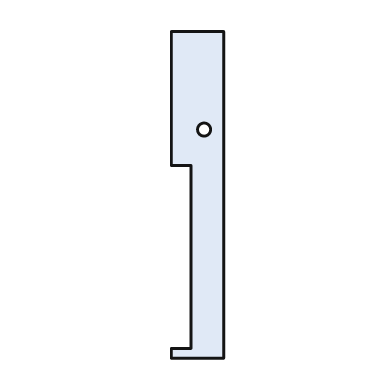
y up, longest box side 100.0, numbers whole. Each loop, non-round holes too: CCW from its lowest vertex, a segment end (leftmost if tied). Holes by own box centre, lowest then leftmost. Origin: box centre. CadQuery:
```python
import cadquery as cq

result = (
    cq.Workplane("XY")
    .moveTo(-8.0, -50.0)
    .lineTo(8.0, -50.0)
    .lineTo(8.0, 50.0)
    .lineTo(-8.0, 50.0)
    .lineTo(-8.0, 9.0)
    .lineTo(-2.0, 9.0)
    .lineTo(-2.0, -47.0)
    .lineTo(-8.0, -47.0)
    .close()
    .moveTo(2.0, 20.0)
    .circle(2.0)
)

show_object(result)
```